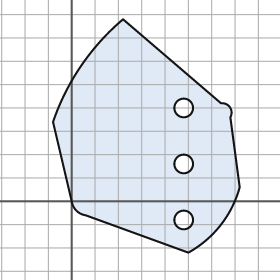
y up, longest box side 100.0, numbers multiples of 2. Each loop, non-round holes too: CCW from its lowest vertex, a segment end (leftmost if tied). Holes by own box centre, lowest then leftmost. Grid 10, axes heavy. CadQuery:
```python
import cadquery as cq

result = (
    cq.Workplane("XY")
    .moveTo(50.0, -22.0)
    .threePointArc((64.0, -10.0), (72.0, 6.0))
    .lineTo(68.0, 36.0)
    .threePointArc((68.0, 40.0), (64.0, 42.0))
    .lineTo(22.0, 78.0)
    .threePointArc((4.0, 58.0), (-8.0, 34.0))
    .lineTo(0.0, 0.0)
    .threePointArc((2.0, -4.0), (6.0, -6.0))
    .close()
    .moveTo(48.0, -8.0)
    .circle(4.0)
    .moveTo(48.0, 16.0)
    .circle(4.0)
    .moveTo(48.0, 40.0)
    .circle(4.0)
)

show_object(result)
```